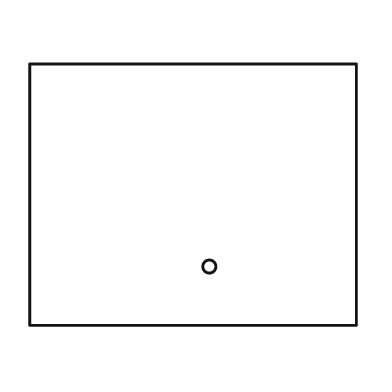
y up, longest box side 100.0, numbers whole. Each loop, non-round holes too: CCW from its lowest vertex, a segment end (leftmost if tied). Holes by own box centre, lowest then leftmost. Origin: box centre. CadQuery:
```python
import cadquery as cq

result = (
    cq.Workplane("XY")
    .moveTo(-50.0, -40.0)
    .lineTo(50.0, -40.0)
    .lineTo(50.0, 40.0)
    .lineTo(-50.0, 40.0)
    .close()
    .moveTo(5.0, -22.0)
    .circle(2.0)
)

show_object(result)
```